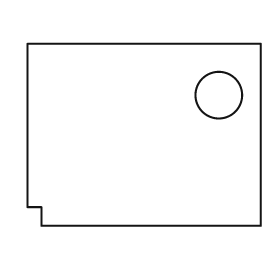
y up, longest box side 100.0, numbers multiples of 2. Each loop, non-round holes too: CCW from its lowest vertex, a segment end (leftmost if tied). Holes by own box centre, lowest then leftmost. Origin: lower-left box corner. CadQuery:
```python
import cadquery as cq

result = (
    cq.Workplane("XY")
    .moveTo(6.0, 0.0)
    .lineTo(100.0, 0.0)
    .lineTo(100.0, 78.0)
    .lineTo(0.0, 78.0)
    .lineTo(0.0, 8.0)
    .lineTo(6.0, 8.0)
    .close()
    .moveTo(82.0, 56.0)
    .circle(10.0)
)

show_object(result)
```